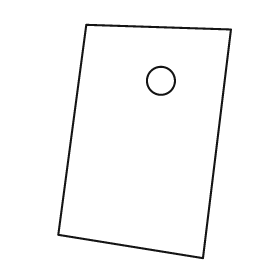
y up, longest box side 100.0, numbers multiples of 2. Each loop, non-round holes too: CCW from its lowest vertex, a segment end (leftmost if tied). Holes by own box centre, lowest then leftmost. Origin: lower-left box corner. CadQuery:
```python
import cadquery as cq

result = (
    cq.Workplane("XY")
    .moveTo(62.0, 0.0)
    .lineTo(74.0, 98.0)
    .lineTo(12.0, 100.0)
    .lineTo(0.0, 10.0)
    .close()
    .moveTo(44.0, 76.0)
    .circle(6.0)
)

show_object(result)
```